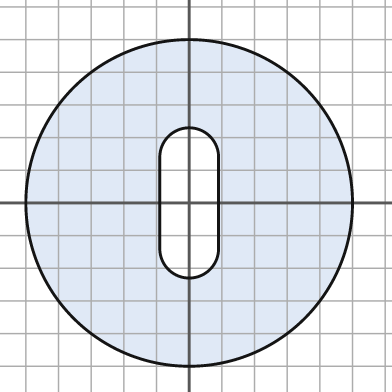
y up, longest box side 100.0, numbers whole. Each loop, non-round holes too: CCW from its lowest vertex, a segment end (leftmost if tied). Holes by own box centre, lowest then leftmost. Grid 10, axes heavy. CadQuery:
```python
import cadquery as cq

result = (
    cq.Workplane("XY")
    .moveTo(0.0, 0.0)
    .circle(50.0)
    .moveTo(-9.0, -14.0)
    .threePointArc((0.0, -23.0), (9.0, -14.0))
    .lineTo(9.0, 14.0)
    .threePointArc((0.0, 23.0), (-9.0, 14.0))
    .close()
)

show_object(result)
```